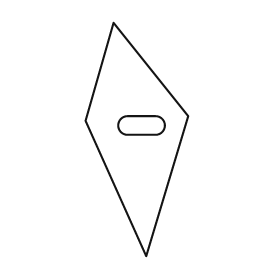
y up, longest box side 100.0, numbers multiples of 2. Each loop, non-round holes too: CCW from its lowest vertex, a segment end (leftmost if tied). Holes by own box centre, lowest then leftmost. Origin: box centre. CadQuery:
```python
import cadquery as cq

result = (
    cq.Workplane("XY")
    .moveTo(4.0, -50.0)
    .lineTo(22.0, 10.0)
    .lineTo(-10.0, 50.0)
    .lineTo(-22.0, 8.0)
    .close()
    .moveTo(-4.0, 2.0)
    .lineTo(8.0, 2.0)
    .threePointArc((12.0, 6.0), (8.0, 10.0))
    .lineTo(-4.0, 10.0)
    .threePointArc((-8.0, 6.0), (-4.0, 2.0))
    .close()
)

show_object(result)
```